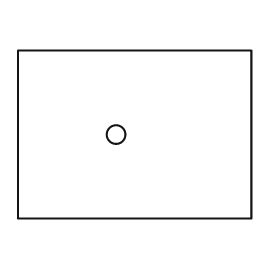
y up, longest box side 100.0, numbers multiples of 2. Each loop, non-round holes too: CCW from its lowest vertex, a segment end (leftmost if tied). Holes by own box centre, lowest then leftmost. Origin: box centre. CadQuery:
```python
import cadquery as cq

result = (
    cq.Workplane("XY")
    .moveTo(-50.0, -36.0)
    .lineTo(50.0, -36.0)
    .lineTo(50.0, 36.0)
    .lineTo(-50.0, 36.0)
    .close()
    .moveTo(-8.0, 0.0)
    .circle(4.0)
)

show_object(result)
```